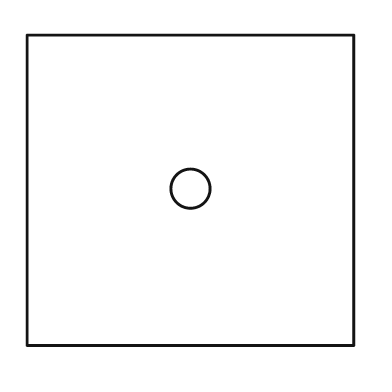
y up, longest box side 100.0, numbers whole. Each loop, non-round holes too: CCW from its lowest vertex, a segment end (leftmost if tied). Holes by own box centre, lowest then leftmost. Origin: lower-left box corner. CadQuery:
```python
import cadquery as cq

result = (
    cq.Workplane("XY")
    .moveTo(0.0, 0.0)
    .lineTo(100.0, 0.0)
    .lineTo(100.0, 95.0)
    .lineTo(0.0, 95.0)
    .close()
    .moveTo(50.0, 48.0)
    .circle(6.0)
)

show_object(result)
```